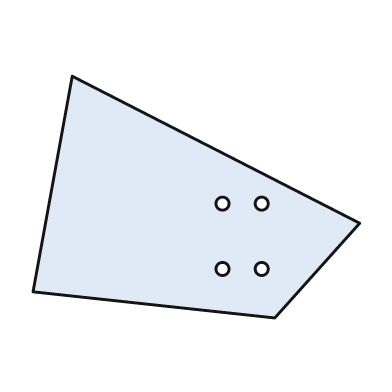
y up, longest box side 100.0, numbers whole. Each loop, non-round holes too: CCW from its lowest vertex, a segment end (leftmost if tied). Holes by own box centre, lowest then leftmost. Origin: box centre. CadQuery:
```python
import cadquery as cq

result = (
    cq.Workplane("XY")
    .moveTo(24.0, -37.0)
    .lineTo(50.0, -8.0)
    .lineTo(-38.0, 37.0)
    .lineTo(-50.0, -29.0)
    .close()
    .moveTo(8.0, -22.0)
    .circle(2.0)
    .moveTo(20.0, -22.0)
    .circle(2.0)
    .moveTo(8.0, -2.0)
    .circle(2.0)
    .moveTo(20.0, -2.0)
    .circle(2.0)
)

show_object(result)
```